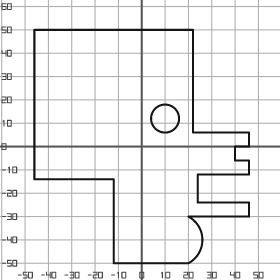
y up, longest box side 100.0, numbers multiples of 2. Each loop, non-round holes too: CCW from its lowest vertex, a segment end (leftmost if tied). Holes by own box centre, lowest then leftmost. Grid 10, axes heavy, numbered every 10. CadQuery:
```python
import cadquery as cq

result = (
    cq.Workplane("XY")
    .moveTo(-12.0, -50.0)
    .lineTo(20.0, -50.0)
    .threePointArc((26.0, -40.0), (20.0, -30.0))
    .lineTo(46.0, -30.0)
    .lineTo(46.0, -24.0)
    .lineTo(24.0, -24.0)
    .lineTo(24.0, -12.0)
    .lineTo(46.0, -12.0)
    .lineTo(46.0, -6.0)
    .lineTo(40.0, -6.0)
    .lineTo(40.0, 0.0)
    .lineTo(46.0, 0.0)
    .lineTo(46.0, 6.0)
    .lineTo(22.0, 6.0)
    .lineTo(22.0, 50.0)
    .lineTo(-46.0, 50.0)
    .lineTo(-46.0, -14.0)
    .lineTo(-12.0, -14.0)
    .close()
    .moveTo(10.0, 12.0)
    .circle(6.0)
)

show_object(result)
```